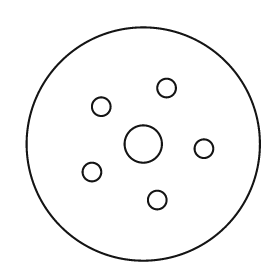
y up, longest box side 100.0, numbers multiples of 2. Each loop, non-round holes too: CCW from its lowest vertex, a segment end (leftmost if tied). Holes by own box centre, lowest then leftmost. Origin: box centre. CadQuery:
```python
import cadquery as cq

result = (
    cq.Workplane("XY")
    .moveTo(0.0, 0.0)
    .circle(50.0)
    .moveTo(6.0, -24.0)
    .circle(4.0)
    .moveTo(-22.0, -12.0)
    .circle(4.0)
    .moveTo(26.0, -2.0)
    .circle(4.0)
    .moveTo(0.0, 0.0)
    .circle(8.0)
    .moveTo(-18.0, 16.0)
    .circle(4.0)
    .moveTo(10.0, 24.0)
    .circle(4.0)
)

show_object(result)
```